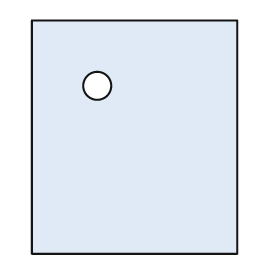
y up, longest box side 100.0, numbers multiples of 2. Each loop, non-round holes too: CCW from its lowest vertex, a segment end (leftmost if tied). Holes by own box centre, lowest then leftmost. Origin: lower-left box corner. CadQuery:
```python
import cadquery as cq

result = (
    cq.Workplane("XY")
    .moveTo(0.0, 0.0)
    .lineTo(88.0, 0.0)
    .lineTo(88.0, 100.0)
    .lineTo(0.0, 100.0)
    .close()
    .moveTo(28.0, 72.0)
    .circle(6.0)
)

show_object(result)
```